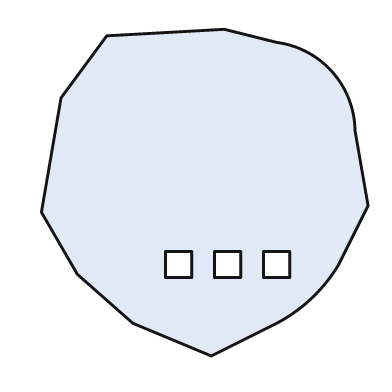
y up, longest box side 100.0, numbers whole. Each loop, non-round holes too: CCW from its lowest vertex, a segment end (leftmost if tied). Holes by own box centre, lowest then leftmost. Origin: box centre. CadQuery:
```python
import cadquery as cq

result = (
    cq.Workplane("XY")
    .moveTo(2.0, -50.0)
    .lineTo(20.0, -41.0)
    .threePointArc((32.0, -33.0), (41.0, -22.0))
    .lineTo(50.0, -4.0)
    .lineTo(46.0, 19.0)
    .threePointArc((39.0, 37.0), (22.0, 46.0))
    .lineTo(6.0, 50.0)
    .lineTo(-30.0, 48.0)
    .lineTo(-44.0, 29.0)
    .lineTo(-50.0, -6.0)
    .lineTo(-39.0, -25.0)
    .lineTo(-22.0, -40.0)
    .close()
    .moveTo(-12.0, -26.0)
    .lineTo(-4.0, -26.0)
    .lineTo(-4.0, -18.0)
    .lineTo(-12.0, -18.0)
    .close()
    .moveTo(3.0, -26.0)
    .lineTo(11.0, -26.0)
    .lineTo(11.0, -18.0)
    .lineTo(3.0, -18.0)
    .close()
    .moveTo(18.0, -26.0)
    .lineTo(26.0, -26.0)
    .lineTo(26.0, -18.0)
    .lineTo(18.0, -18.0)
    .close()
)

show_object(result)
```